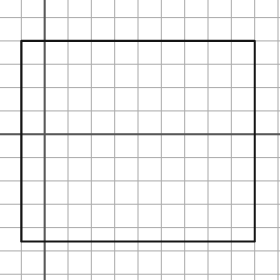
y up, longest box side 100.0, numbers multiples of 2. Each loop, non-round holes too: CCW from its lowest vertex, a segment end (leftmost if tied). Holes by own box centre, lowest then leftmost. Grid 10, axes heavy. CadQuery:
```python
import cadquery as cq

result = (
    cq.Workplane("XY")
    .moveTo(-10.0, -46.0)
    .lineTo(90.0, -46.0)
    .lineTo(90.0, 40.0)
    .lineTo(-10.0, 40.0)
    .close()
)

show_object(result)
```